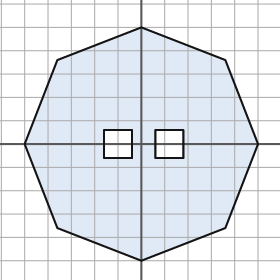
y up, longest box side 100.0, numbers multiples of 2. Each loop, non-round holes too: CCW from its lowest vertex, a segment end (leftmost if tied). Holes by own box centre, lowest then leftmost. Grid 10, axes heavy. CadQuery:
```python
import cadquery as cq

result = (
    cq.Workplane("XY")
    .moveTo(0.0, -50.0)
    .lineTo(36.0, -36.0)
    .lineTo(50.0, 0.0)
    .lineTo(36.0, 36.0)
    .lineTo(0.0, 50.0)
    .lineTo(-36.0, 36.0)
    .lineTo(-50.0, 0.0)
    .lineTo(-36.0, -36.0)
    .close()
    .moveTo(-16.0, -6.0)
    .lineTo(-4.0, -6.0)
    .lineTo(-4.0, 6.0)
    .lineTo(-16.0, 6.0)
    .close()
    .moveTo(6.0, -6.0)
    .lineTo(18.0, -6.0)
    .lineTo(18.0, 6.0)
    .lineTo(6.0, 6.0)
    .close()
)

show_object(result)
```